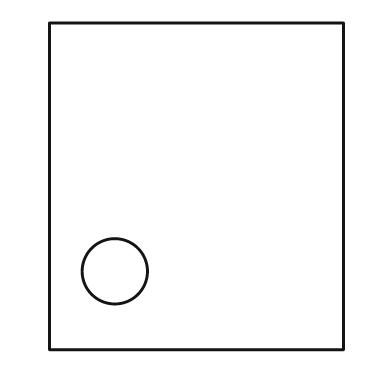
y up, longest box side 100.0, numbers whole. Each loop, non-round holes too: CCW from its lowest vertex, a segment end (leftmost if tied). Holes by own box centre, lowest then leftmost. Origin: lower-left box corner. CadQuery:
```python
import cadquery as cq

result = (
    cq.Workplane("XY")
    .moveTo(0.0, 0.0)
    .lineTo(90.0, 0.0)
    .lineTo(90.0, 100.0)
    .lineTo(0.0, 100.0)
    .close()
    .moveTo(20.0, 24.0)
    .circle(10.0)
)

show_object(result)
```